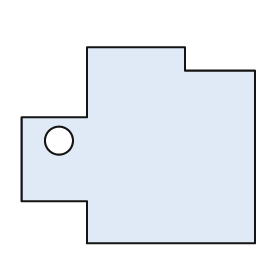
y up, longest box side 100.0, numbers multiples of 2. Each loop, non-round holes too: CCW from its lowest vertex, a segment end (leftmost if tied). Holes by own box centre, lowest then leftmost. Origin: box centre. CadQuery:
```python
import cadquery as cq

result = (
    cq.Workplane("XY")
    .moveTo(-22.0, -42.0)
    .lineTo(50.0, -42.0)
    .lineTo(50.0, 32.0)
    .lineTo(20.0, 32.0)
    .lineTo(20.0, 42.0)
    .lineTo(-22.0, 42.0)
    .lineTo(-22.0, 12.0)
    .lineTo(-50.0, 12.0)
    .lineTo(-50.0, -24.0)
    .lineTo(-22.0, -24.0)
    .close()
    .moveTo(-34.0, 2.0)
    .circle(6.0)
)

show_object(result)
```